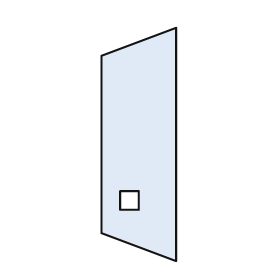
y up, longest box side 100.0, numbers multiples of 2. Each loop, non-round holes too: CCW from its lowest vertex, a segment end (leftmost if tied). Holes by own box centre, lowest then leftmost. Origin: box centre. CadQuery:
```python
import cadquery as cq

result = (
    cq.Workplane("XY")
    .moveTo(16.0, -50.0)
    .lineTo(16.0, 50.0)
    .lineTo(-16.0, 38.0)
    .lineTo(-16.0, -38.0)
    .close()
    .moveTo(-8.0, -28.0)
    .lineTo(0.0, -28.0)
    .lineTo(0.0, -20.0)
    .lineTo(-8.0, -20.0)
    .close()
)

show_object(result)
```